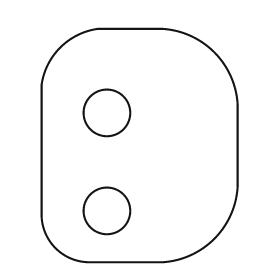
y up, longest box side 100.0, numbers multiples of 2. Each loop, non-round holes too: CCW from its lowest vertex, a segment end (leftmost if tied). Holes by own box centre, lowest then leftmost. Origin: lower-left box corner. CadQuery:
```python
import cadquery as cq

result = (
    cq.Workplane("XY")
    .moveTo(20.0, 0.0)
    .lineTo(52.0, 0.0)
    .threePointArc((74.0, 10.0), (84.0, 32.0))
    .lineTo(84.0, 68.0)
    .threePointArc((74.0, 90.0), (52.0, 100.0))
    .lineTo(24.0, 100.0)
    .threePointArc((8.0, 92.0), (0.0, 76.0))
    .lineTo(0.0, 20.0)
    .threePointArc((6.0, 6.0), (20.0, 0.0))
    .close()
    .moveTo(28.0, 22.0)
    .circle(10.0)
    .moveTo(28.0, 64.0)
    .circle(10.0)
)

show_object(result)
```